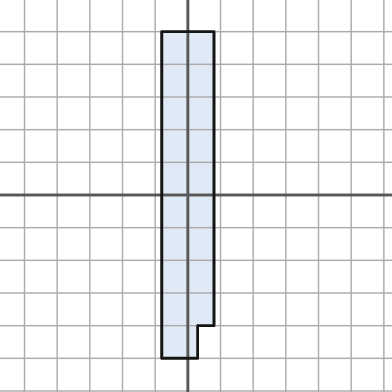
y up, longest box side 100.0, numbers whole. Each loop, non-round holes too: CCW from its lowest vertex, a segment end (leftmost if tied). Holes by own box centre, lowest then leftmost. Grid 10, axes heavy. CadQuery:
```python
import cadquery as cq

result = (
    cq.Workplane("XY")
    .moveTo(-8.0, -50.0)
    .lineTo(3.0, -50.0)
    .lineTo(3.0, -40.0)
    .lineTo(8.0, -40.0)
    .lineTo(8.0, 50.0)
    .lineTo(-8.0, 50.0)
    .close()
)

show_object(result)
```